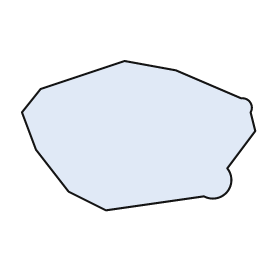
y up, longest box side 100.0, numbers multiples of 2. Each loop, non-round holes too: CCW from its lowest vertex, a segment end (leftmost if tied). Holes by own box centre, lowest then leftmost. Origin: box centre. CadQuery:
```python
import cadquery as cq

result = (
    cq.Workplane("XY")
    .moveTo(-14.0, -32.0)
    .lineTo(28.0, -26.0)
    .threePointArc((38.0, -24.0), (38.0, -14.0))
    .lineTo(50.0, 2.0)
    .lineTo(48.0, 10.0)
    .threePointArc((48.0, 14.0), (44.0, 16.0))
    .lineTo(16.0, 28.0)
    .lineTo(-6.0, 32.0)
    .lineTo(-42.0, 20.0)
    .lineTo(-50.0, 10.0)
    .lineTo(-44.0, -6.0)
    .lineTo(-30.0, -24.0)
    .close()
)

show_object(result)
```